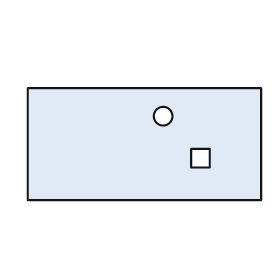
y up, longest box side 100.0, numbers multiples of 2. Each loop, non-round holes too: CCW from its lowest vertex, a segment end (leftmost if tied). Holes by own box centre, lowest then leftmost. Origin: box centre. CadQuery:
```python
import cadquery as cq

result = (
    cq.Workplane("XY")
    .moveTo(-50.0, -24.0)
    .lineTo(50.0, -24.0)
    .lineTo(50.0, 24.0)
    .lineTo(-50.0, 24.0)
    .close()
    .moveTo(20.0, -10.0)
    .lineTo(28.0, -10.0)
    .lineTo(28.0, -2.0)
    .lineTo(20.0, -2.0)
    .close()
    .moveTo(8.0, 12.0)
    .circle(4.0)
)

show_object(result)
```